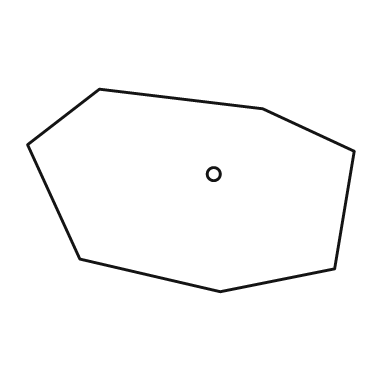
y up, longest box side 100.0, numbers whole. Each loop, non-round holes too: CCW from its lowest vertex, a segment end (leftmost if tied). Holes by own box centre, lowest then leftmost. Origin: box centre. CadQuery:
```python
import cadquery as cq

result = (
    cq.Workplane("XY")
    .moveTo(9.0, -31.0)
    .lineTo(44.0, -24.0)
    .lineTo(50.0, 12.0)
    .lineTo(22.0, 25.0)
    .lineTo(-28.0, 31.0)
    .lineTo(-50.0, 14.0)
    .lineTo(-34.0, -21.0)
    .close()
    .moveTo(7.0, 5.0)
    .circle(2.0)
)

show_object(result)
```